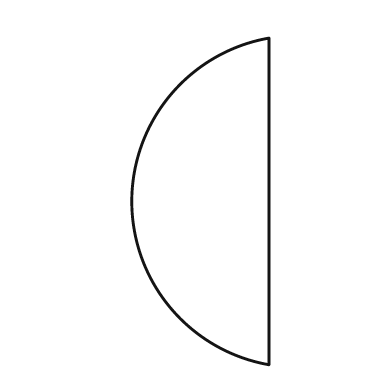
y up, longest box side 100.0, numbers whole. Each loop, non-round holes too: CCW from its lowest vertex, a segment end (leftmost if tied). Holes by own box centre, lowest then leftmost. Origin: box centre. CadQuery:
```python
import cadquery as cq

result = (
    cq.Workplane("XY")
    .moveTo(21.0, -50.0)
    .lineTo(21.0, 50.0)
    .threePointArc((-21.0, 0.0), (21.0, -50.0))
    .close()
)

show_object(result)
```